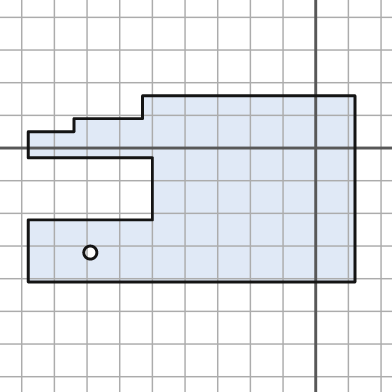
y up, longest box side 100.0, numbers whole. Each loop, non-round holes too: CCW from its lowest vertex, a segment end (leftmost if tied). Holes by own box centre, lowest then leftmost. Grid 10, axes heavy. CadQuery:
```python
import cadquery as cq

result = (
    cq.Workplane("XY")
    .moveTo(-88.0, -41.0)
    .lineTo(12.0, -41.0)
    .lineTo(12.0, 16.0)
    .lineTo(-53.0, 16.0)
    .lineTo(-53.0, 9.0)
    .lineTo(-74.0, 9.0)
    .lineTo(-74.0, 5.0)
    .lineTo(-88.0, 5.0)
    .lineTo(-88.0, -3.0)
    .lineTo(-50.0, -3.0)
    .lineTo(-50.0, -22.0)
    .lineTo(-88.0, -22.0)
    .close()
    .moveTo(-69.0, -32.0)
    .circle(2.0)
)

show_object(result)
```